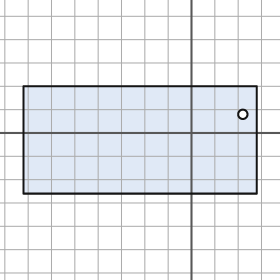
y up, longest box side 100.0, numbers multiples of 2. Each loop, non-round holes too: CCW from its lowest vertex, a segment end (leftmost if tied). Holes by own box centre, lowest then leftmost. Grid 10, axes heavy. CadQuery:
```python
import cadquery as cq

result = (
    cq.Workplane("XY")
    .moveTo(-72.0, -26.0)
    .lineTo(28.0, -26.0)
    .lineTo(28.0, 20.0)
    .lineTo(-72.0, 20.0)
    .close()
    .moveTo(22.0, 8.0)
    .circle(2.0)
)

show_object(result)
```